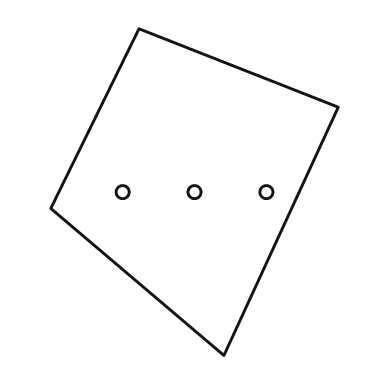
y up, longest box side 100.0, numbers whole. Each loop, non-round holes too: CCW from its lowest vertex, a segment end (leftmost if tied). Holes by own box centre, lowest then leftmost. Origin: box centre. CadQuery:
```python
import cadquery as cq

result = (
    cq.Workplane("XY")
    .moveTo(9.0, -50.0)
    .lineTo(44.0, 26.0)
    .lineTo(-17.0, 50.0)
    .lineTo(-44.0, -5.0)
    .close()
    .moveTo(-22.0, 0.0)
    .circle(2.0)
    .moveTo(0.0, 0.0)
    .circle(2.0)
    .moveTo(22.0, 0.0)
    .circle(2.0)
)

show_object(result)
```